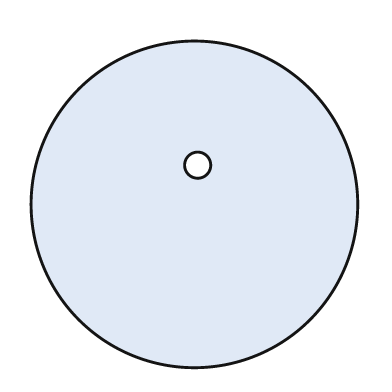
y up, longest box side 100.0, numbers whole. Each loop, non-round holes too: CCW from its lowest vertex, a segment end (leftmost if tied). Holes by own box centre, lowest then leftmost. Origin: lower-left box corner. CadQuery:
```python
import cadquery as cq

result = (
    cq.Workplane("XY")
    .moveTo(50.0, 50.0)
    .circle(50.0)
    .moveTo(51.0, 62.0)
    .circle(4.0)
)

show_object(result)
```